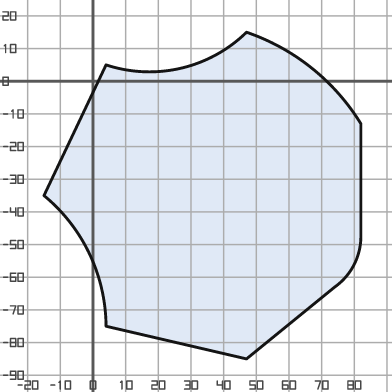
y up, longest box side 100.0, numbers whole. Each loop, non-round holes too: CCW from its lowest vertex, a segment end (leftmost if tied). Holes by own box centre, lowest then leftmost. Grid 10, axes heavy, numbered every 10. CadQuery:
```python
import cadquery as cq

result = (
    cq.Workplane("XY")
    .moveTo(47.0, -85.0)
    .lineTo(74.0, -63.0)
    .threePointArc((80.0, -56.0), (82.0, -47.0))
    .lineTo(82.0, -13.0)
    .threePointArc((67.0, 4.0), (47.0, 15.0))
    .threePointArc((27.0, 4.0), (4.0, 5.0))
    .lineTo(-15.0, -35.0)
    .threePointArc((-1.0, -53.0), (4.0, -75.0))
    .close()
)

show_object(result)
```